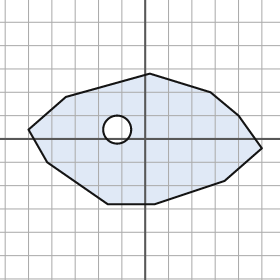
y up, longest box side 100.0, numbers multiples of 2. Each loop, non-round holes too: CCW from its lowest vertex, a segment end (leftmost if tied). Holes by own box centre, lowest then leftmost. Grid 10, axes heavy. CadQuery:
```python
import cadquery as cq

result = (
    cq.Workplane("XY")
    .moveTo(-16.0, -28.0)
    .lineTo(4.0, -28.0)
    .lineTo(34.0, -18.0)
    .lineTo(50.0, -4.0)
    .lineTo(40.0, 10.0)
    .lineTo(28.0, 20.0)
    .lineTo(2.0, 28.0)
    .lineTo(-34.0, 18.0)
    .lineTo(-50.0, 4.0)
    .lineTo(-42.0, -10.0)
    .close()
    .moveTo(-12.0, 4.0)
    .circle(6.0)
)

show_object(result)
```